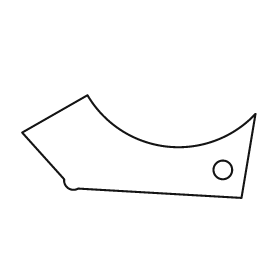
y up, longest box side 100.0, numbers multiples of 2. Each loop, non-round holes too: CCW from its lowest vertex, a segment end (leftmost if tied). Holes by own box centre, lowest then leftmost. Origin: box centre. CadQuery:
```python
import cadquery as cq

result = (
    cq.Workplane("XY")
    .moveTo(44.0, -22.0)
    .lineTo(50.0, 14.0)
    .threePointArc((12.0, 0.0), (-22.0, 22.0))
    .lineTo(-50.0, 6.0)
    .lineTo(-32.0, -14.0)
    .threePointArc((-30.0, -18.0), (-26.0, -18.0))
    .close()
    .moveTo(36.0, -10.0)
    .circle(4.0)
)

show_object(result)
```